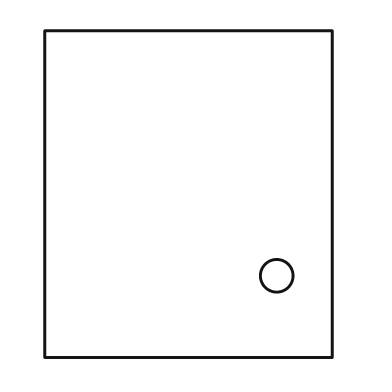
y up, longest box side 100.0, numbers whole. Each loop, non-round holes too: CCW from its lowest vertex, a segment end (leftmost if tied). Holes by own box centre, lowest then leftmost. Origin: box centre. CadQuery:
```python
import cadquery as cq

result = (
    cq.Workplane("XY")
    .moveTo(-44.0, -50.0)
    .lineTo(44.0, -50.0)
    .lineTo(44.0, 50.0)
    .lineTo(-44.0, 50.0)
    .close()
    .moveTo(27.0, -25.0)
    .circle(5.0)
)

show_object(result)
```